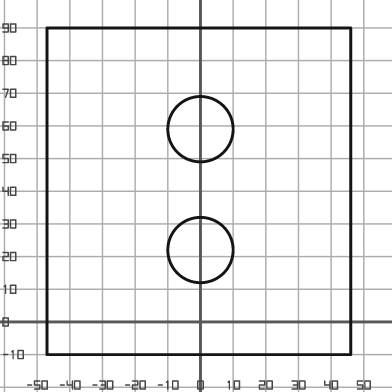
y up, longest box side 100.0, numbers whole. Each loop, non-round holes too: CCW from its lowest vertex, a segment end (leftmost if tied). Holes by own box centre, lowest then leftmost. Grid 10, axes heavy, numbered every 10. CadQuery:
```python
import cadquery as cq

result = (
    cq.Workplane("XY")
    .moveTo(-47.0, -10.0)
    .lineTo(46.0, -10.0)
    .lineTo(46.0, 90.0)
    .lineTo(-47.0, 90.0)
    .close()
    .moveTo(0.0, 22.0)
    .circle(10.0)
    .moveTo(0.0, 59.0)
    .circle(10.0)
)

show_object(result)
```